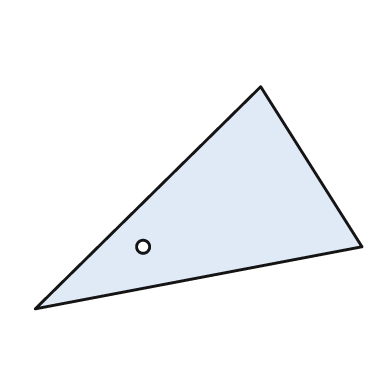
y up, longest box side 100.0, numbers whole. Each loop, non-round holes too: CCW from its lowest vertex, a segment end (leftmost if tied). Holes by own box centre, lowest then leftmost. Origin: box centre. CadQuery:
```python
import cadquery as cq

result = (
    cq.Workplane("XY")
    .moveTo(-50.0, -34.0)
    .lineTo(50.0, -15.0)
    .lineTo(19.0, 34.0)
    .close()
    .moveTo(-17.0, -15.0)
    .circle(2.0)
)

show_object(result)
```